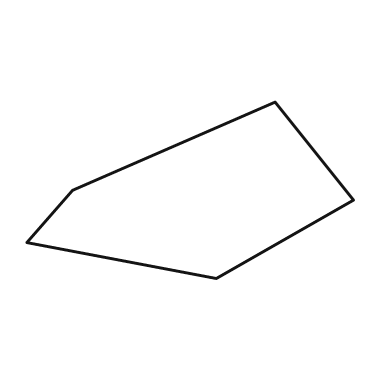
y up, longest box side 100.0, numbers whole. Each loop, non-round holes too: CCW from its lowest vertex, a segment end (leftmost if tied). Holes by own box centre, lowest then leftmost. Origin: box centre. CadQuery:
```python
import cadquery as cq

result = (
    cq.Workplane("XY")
    .moveTo(8.0, -27.0)
    .lineTo(50.0, -3.0)
    .lineTo(26.0, 27.0)
    .lineTo(-36.0, 0.0)
    .lineTo(-50.0, -16.0)
    .close()
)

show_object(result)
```